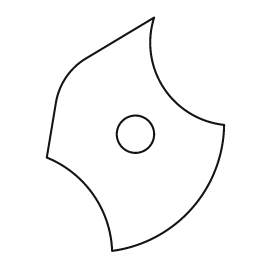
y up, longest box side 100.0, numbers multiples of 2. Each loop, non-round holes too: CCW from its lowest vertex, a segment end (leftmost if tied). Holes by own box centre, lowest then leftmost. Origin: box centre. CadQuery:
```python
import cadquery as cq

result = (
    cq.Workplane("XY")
    .moveTo(-10.0, -50.0)
    .threePointArc((24.0, -32.0), (38.0, 4.0))
    .threePointArc((12.0, 20.0), (8.0, 50.0))
    .lineTo(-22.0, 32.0)
    .threePointArc((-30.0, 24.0), (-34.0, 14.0))
    .lineTo(-38.0, -10.0)
    .threePointArc((-18.0, -26.0), (-10.0, -50.0))
    .close()
    .moveTo(0.0, 0.0)
    .circle(8.0)
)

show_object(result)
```